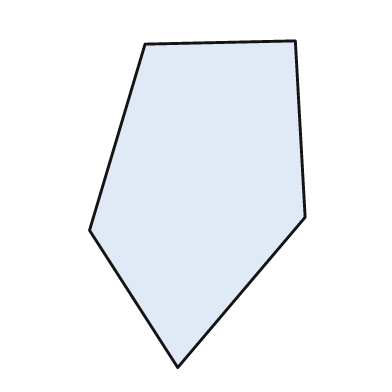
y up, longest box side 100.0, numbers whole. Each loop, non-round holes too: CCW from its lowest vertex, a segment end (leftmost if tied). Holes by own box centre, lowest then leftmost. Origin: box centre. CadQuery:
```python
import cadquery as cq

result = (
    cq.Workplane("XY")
    .moveTo(-6.0, -50.0)
    .lineTo(33.0, -4.0)
    .lineTo(30.0, 50.0)
    .lineTo(-16.0, 49.0)
    .lineTo(-33.0, -8.0)
    .close()
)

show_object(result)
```